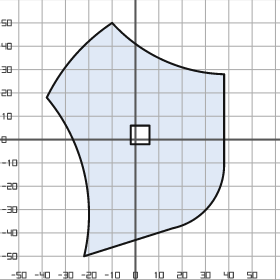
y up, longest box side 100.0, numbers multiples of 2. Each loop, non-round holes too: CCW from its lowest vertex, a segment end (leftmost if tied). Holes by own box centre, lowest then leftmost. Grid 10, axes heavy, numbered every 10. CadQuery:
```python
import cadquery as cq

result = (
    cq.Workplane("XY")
    .moveTo(-22.0, -50.0)
    .lineTo(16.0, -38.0)
    .threePointArc((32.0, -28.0), (38.0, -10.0))
    .lineTo(38.0, 28.0)
    .threePointArc((12.0, 34.0), (-10.0, 50.0))
    .threePointArc((-26.0, 36.0), (-38.0, 18.0))
    .threePointArc((-22.0, -14.0), (-22.0, -50.0))
    .close()
    .moveTo(-2.0, -2.0)
    .lineTo(6.0, -2.0)
    .lineTo(6.0, 6.0)
    .lineTo(-2.0, 6.0)
    .close()
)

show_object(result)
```